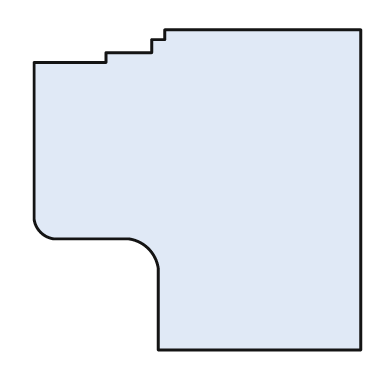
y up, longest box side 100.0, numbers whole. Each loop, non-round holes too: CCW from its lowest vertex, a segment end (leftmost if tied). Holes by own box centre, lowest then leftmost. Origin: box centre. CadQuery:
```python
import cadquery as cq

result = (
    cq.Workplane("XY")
    .moveTo(-12.0, -49.0)
    .lineTo(50.0, -49.0)
    .lineTo(50.0, 49.0)
    .lineTo(-10.0, 49.0)
    .lineTo(-10.0, 46.0)
    .lineTo(-14.0, 46.0)
    .lineTo(-14.0, 42.0)
    .lineTo(-28.0, 42.0)
    .lineTo(-28.0, 39.0)
    .lineTo(-50.0, 39.0)
    .lineTo(-50.0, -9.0)
    .threePointArc((-48.0, -13.0), (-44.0, -15.0))
    .lineTo(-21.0, -15.0)
    .threePointArc((-15.0, -18.0), (-12.0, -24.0))
    .close()
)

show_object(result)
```